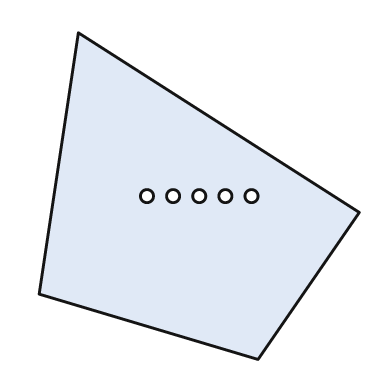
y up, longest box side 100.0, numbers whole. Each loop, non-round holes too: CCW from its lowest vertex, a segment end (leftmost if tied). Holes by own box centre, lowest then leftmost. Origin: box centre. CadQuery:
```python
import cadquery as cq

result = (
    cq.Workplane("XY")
    .moveTo(18.0, -50.0)
    .lineTo(49.0, -5.0)
    .lineTo(-37.0, 50.0)
    .lineTo(-49.0, -30.0)
    .close()
    .moveTo(-16.0, 0.0)
    .circle(2.0)
    .moveTo(-8.0, 0.0)
    .circle(2.0)
    .moveTo(0.0, 0.0)
    .circle(2.0)
    .moveTo(8.0, 0.0)
    .circle(2.0)
    .moveTo(16.0, 0.0)
    .circle(2.0)
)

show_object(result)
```